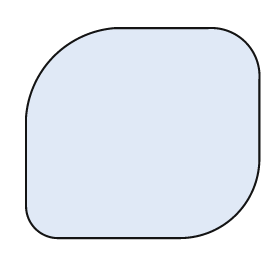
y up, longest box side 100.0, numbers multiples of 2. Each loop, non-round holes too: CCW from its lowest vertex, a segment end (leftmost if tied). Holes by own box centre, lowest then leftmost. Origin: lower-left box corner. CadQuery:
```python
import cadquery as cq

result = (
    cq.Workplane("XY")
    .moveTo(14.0, 0.0)
    .lineTo(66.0, 0.0)
    .threePointArc((90.0, 10.0), (100.0, 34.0))
    .lineTo(100.0, 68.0)
    .threePointArc((94.0, 84.0), (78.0, 90.0))
    .lineTo(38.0, 90.0)
    .threePointArc((12.0, 78.0), (0.0, 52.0))
    .lineTo(0.0, 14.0)
    .threePointArc((4.0, 4.0), (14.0, 0.0))
    .close()
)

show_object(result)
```